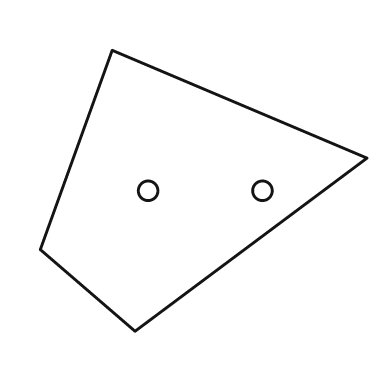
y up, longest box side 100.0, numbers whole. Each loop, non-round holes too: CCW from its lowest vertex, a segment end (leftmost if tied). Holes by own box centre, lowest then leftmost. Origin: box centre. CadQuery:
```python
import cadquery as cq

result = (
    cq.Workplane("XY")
    .moveTo(-21.0, -43.0)
    .lineTo(50.0, 10.0)
    .lineTo(-28.0, 43.0)
    .lineTo(-50.0, -18.0)
    .close()
    .moveTo(-17.0, 0.0)
    .circle(3.0)
    .moveTo(18.0, 0.0)
    .circle(3.0)
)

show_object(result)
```